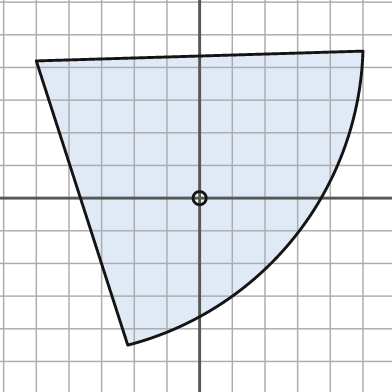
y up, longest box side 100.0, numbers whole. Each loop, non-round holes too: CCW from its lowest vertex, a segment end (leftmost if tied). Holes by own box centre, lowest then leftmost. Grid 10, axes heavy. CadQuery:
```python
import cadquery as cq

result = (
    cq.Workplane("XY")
    .moveTo(-22.0, -45.0)
    .threePointArc((29.0, -12.0), (50.0, 45.0))
    .lineTo(-50.0, 42.0)
    .close()
    .moveTo(0.0, 0.0)
    .circle(2.0)
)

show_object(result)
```